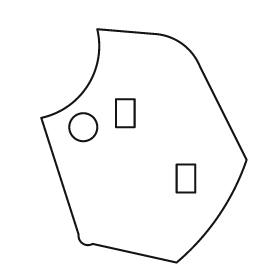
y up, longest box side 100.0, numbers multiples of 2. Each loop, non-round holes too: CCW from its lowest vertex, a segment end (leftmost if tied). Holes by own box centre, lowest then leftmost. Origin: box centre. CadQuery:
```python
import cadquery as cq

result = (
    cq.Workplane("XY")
    .moveTo(14.0, -50.0)
    .threePointArc((32.0, -30.0), (44.0, -6.0))
    .lineTo(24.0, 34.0)
    .threePointArc((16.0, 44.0), (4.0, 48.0))
    .lineTo(-20.0, 50.0)
    .threePointArc((-24.0, 26.0), (-44.0, 12.0))
    .lineTo(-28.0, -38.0)
    .threePointArc((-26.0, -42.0), (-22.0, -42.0))
    .close()
    .moveTo(14.0, -20.0)
    .lineTo(22.0, -20.0)
    .lineTo(22.0, -8.0)
    .lineTo(14.0, -8.0)
    .close()
    .moveTo(-26.0, 8.0)
    .circle(6.0)
    .moveTo(-12.0, 8.0)
    .lineTo(-4.0, 8.0)
    .lineTo(-4.0, 20.0)
    .lineTo(-12.0, 20.0)
    .close()
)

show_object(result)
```